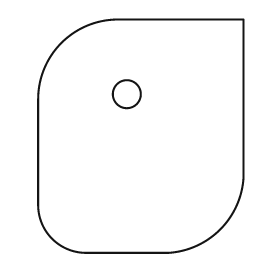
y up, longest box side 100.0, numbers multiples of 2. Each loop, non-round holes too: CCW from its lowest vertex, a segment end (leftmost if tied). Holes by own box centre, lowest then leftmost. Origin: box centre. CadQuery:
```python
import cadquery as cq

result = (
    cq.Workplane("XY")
    .moveTo(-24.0, -50.0)
    .lineTo(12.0, -50.0)
    .threePointArc((34.0, -40.0), (44.0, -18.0))
    .lineTo(44.0, 50.0)
    .lineTo(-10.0, 50.0)
    .threePointArc((-34.0, 40.0), (-44.0, 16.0))
    .lineTo(-44.0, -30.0)
    .threePointArc((-38.0, -44.0), (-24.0, -50.0))
    .close()
    .moveTo(-6.0, 18.0)
    .circle(6.0)
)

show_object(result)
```